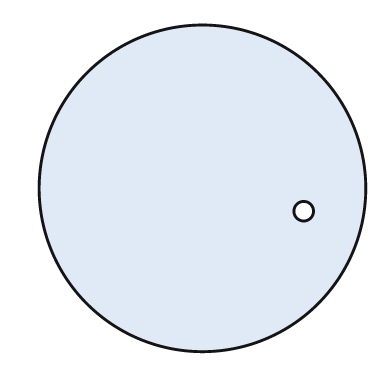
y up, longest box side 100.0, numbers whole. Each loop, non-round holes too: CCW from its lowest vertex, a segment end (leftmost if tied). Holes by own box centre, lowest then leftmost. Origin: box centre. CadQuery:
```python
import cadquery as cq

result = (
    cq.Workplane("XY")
    .moveTo(0.0, 0.0)
    .circle(50.0)
    .moveTo(31.0, -7.0)
    .circle(3.0)
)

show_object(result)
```